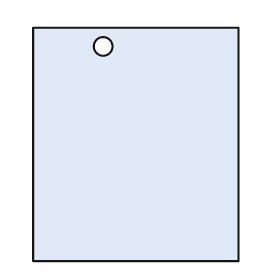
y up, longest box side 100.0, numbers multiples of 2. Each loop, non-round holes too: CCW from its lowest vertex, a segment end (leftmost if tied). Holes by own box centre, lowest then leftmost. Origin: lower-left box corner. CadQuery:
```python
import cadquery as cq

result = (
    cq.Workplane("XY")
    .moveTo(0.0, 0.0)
    .lineTo(88.0, 0.0)
    .lineTo(88.0, 100.0)
    .lineTo(0.0, 100.0)
    .close()
    .moveTo(30.0, 92.0)
    .circle(4.0)
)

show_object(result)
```